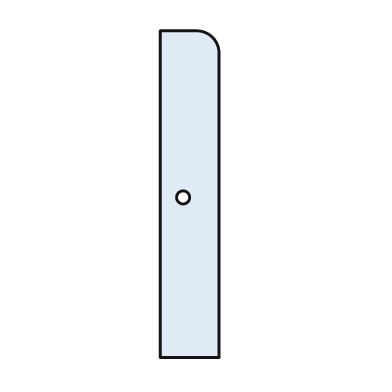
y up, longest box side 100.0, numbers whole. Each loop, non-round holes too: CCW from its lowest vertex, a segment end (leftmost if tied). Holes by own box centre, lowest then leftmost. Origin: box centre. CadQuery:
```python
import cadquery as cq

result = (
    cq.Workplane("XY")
    .moveTo(-9.0, -50.0)
    .lineTo(9.0, -50.0)
    .lineTo(9.0, 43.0)
    .threePointArc((7.0, 48.0), (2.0, 50.0))
    .lineTo(-9.0, 50.0)
    .close()
    .moveTo(-2.0, -1.0)
    .circle(2.0)
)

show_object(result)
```